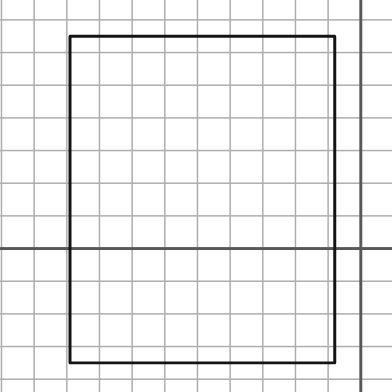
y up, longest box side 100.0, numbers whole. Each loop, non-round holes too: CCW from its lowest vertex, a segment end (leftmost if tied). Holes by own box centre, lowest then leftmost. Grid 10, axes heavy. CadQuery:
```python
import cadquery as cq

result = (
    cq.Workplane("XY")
    .moveTo(-89.0, -35.0)
    .lineTo(-8.0, -35.0)
    .lineTo(-8.0, 65.0)
    .lineTo(-89.0, 65.0)
    .close()
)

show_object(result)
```